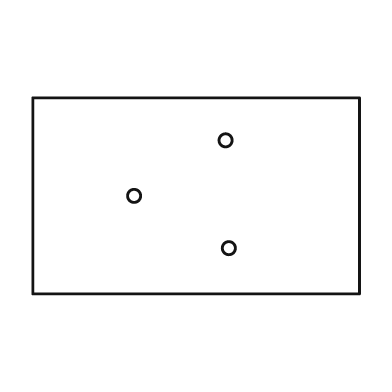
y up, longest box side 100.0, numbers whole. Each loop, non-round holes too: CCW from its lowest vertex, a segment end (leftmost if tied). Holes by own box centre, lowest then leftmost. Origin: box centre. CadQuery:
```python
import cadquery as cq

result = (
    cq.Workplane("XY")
    .moveTo(-50.0, -30.0)
    .lineTo(50.0, -30.0)
    .lineTo(50.0, 30.0)
    .lineTo(-50.0, 30.0)
    .close()
    .moveTo(10.0, -16.0)
    .circle(2.0)
    .moveTo(-19.0, 0.0)
    .circle(2.0)
    .moveTo(9.0, 17.0)
    .circle(2.0)
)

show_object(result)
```